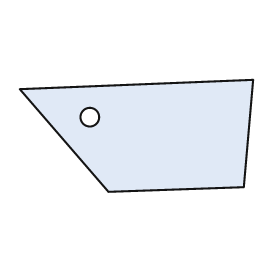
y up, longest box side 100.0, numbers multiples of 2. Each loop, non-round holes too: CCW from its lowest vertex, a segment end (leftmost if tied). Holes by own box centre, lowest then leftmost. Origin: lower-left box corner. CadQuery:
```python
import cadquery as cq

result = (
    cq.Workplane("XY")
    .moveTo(38.0, 0.0)
    .lineTo(96.0, 2.0)
    .lineTo(100.0, 48.0)
    .lineTo(0.0, 44.0)
    .close()
    .moveTo(30.0, 32.0)
    .circle(4.0)
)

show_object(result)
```